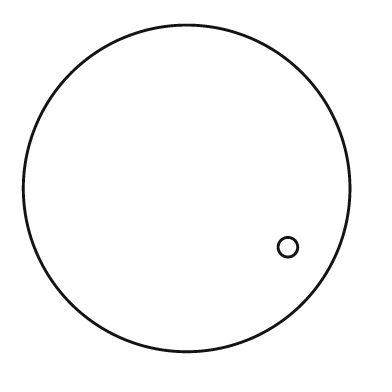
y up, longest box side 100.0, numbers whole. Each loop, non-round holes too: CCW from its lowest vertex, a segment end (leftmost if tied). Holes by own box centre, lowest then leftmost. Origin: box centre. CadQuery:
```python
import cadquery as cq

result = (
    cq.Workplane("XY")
    .moveTo(0.0, 0.0)
    .circle(50.0)
    .moveTo(31.0, -18.0)
    .circle(3.0)
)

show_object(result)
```